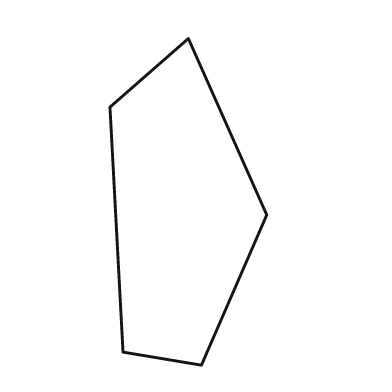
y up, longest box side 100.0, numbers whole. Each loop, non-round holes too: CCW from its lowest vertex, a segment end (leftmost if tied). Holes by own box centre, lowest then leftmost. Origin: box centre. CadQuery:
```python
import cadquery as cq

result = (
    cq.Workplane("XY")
    .moveTo(4.0, -50.0)
    .lineTo(24.0, -4.0)
    .lineTo(0.0, 50.0)
    .lineTo(-24.0, 29.0)
    .lineTo(-20.0, -46.0)
    .close()
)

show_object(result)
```